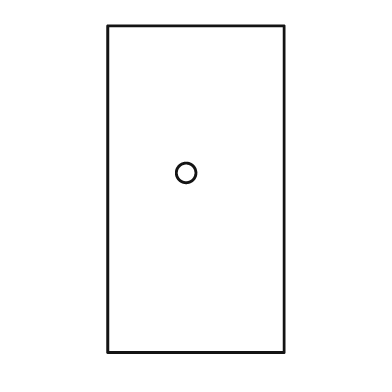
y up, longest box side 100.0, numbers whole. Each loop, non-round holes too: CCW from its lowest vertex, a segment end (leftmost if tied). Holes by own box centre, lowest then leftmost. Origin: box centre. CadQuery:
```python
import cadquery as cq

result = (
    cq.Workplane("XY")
    .moveTo(-27.0, -50.0)
    .lineTo(27.0, -50.0)
    .lineTo(27.0, 50.0)
    .lineTo(-27.0, 50.0)
    .close()
    .moveTo(-3.0, 5.0)
    .circle(3.0)
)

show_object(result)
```